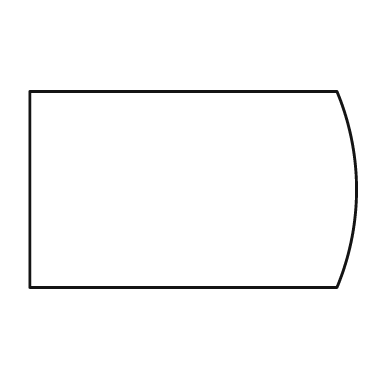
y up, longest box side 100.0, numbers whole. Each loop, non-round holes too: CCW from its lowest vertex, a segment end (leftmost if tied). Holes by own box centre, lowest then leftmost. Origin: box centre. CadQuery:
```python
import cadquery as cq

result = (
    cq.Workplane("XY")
    .moveTo(-50.0, -30.0)
    .lineTo(44.0, -30.0)
    .threePointArc((50.0, 0.0), (44.0, 30.0))
    .lineTo(-50.0, 30.0)
    .close()
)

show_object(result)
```